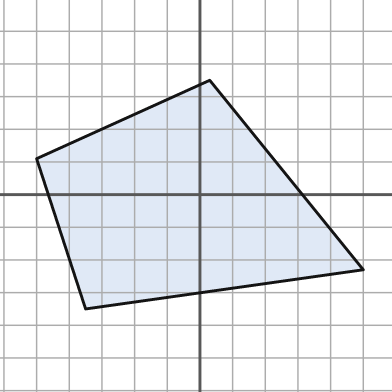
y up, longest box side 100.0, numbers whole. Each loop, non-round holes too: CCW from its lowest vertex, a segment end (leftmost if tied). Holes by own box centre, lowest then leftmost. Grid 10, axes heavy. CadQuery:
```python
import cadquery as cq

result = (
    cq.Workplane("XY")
    .moveTo(-35.0, -35.0)
    .lineTo(50.0, -23.0)
    .lineTo(3.0, 35.0)
    .lineTo(-50.0, 11.0)
    .close()
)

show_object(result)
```